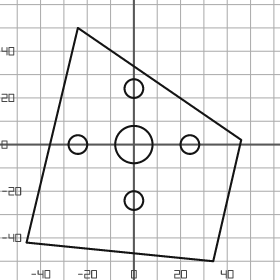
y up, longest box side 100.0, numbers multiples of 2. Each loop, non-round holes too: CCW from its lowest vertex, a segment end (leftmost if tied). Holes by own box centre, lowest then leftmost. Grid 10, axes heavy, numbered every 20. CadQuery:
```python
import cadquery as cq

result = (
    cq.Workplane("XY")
    .moveTo(34.0, -50.0)
    .lineTo(46.0, 2.0)
    .lineTo(-24.0, 50.0)
    .lineTo(-46.0, -42.0)
    .close()
    .moveTo(0.0, -24.0)
    .circle(4.0)
    .moveTo(-24.0, 0.0)
    .circle(4.0)
    .moveTo(0.0, 0.0)
    .circle(8.0)
    .moveTo(24.0, 0.0)
    .circle(4.0)
    .moveTo(0.0, 24.0)
    .circle(4.0)
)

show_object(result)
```